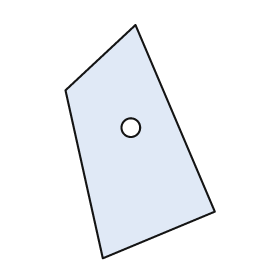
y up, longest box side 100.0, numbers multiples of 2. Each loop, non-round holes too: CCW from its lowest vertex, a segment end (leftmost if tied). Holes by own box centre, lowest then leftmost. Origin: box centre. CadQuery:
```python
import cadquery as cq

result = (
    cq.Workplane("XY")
    .moveTo(-16.0, -50.0)
    .lineTo(32.0, -30.0)
    .lineTo(-2.0, 50.0)
    .lineTo(-32.0, 22.0)
    .close()
    .moveTo(-4.0, 6.0)
    .circle(4.0)
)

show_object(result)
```